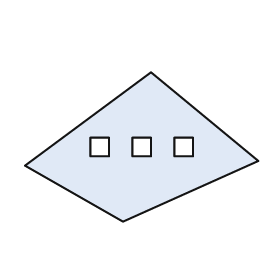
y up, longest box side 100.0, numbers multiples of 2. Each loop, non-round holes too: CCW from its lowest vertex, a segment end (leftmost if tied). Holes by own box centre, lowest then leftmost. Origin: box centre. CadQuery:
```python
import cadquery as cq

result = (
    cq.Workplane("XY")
    .moveTo(-8.0, -32.0)
    .lineTo(50.0, -6.0)
    .lineTo(4.0, 32.0)
    .lineTo(-50.0, -8.0)
    .close()
    .moveTo(-22.0, -4.0)
    .lineTo(-14.0, -4.0)
    .lineTo(-14.0, 4.0)
    .lineTo(-22.0, 4.0)
    .close()
    .moveTo(-4.0, -4.0)
    .lineTo(4.0, -4.0)
    .lineTo(4.0, 4.0)
    .lineTo(-4.0, 4.0)
    .close()
    .moveTo(14.0, -4.0)
    .lineTo(22.0, -4.0)
    .lineTo(22.0, 4.0)
    .lineTo(14.0, 4.0)
    .close()
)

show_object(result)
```